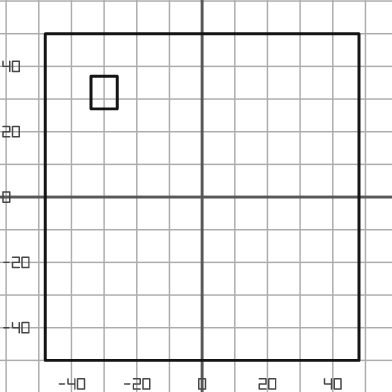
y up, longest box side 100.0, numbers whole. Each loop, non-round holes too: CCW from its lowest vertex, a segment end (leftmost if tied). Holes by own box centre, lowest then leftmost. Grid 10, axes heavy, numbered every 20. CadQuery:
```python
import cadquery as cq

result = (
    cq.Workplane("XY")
    .moveTo(-48.0, -50.0)
    .lineTo(48.0, -50.0)
    .lineTo(48.0, 50.0)
    .lineTo(-48.0, 50.0)
    .close()
    .moveTo(-34.0, 27.0)
    .lineTo(-26.0, 27.0)
    .lineTo(-26.0, 37.0)
    .lineTo(-34.0, 37.0)
    .close()
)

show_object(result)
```